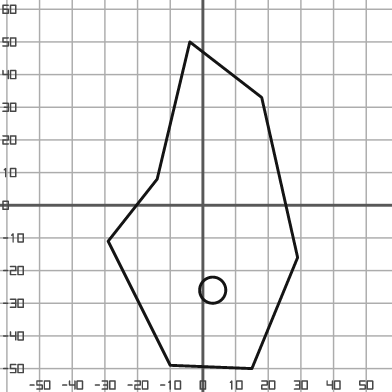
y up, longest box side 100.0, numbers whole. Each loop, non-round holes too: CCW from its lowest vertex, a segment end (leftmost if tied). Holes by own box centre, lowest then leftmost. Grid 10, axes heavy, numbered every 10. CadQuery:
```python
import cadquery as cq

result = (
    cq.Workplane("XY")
    .moveTo(15.0, -50.0)
    .lineTo(29.0, -16.0)
    .lineTo(18.0, 33.0)
    .lineTo(-4.0, 50.0)
    .lineTo(-14.0, 8.0)
    .lineTo(-29.0, -11.0)
    .lineTo(-10.0, -49.0)
    .close()
    .moveTo(3.0, -26.0)
    .circle(4.0)
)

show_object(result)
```